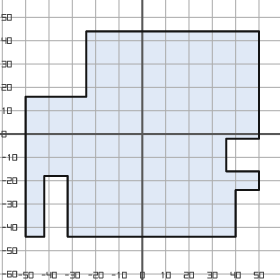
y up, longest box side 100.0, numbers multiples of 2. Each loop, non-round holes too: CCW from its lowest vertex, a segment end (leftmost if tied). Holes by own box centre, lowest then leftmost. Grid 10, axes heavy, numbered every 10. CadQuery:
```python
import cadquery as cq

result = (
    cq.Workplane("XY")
    .moveTo(-50.0, -44.0)
    .lineTo(-42.0, -44.0)
    .lineTo(-42.0, -18.0)
    .lineTo(-32.0, -18.0)
    .lineTo(-32.0, -44.0)
    .lineTo(40.0, -44.0)
    .lineTo(40.0, -24.0)
    .lineTo(50.0, -24.0)
    .lineTo(50.0, -16.0)
    .lineTo(36.0, -16.0)
    .lineTo(36.0, -2.0)
    .lineTo(50.0, -2.0)
    .lineTo(50.0, 44.0)
    .lineTo(-24.0, 44.0)
    .lineTo(-24.0, 16.0)
    .lineTo(-50.0, 16.0)
    .close()
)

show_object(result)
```